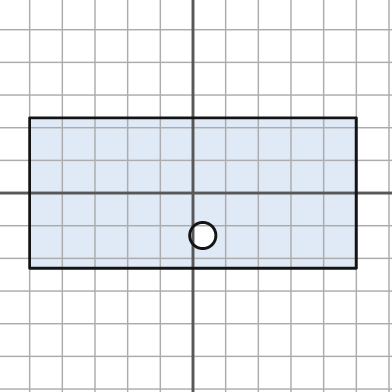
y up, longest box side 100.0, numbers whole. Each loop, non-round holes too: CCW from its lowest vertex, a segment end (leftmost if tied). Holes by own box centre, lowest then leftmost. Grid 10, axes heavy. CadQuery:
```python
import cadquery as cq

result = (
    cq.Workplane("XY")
    .moveTo(-50.0, -23.0)
    .lineTo(50.0, -23.0)
    .lineTo(50.0, 23.0)
    .lineTo(-50.0, 23.0)
    .close()
    .moveTo(3.0, -13.0)
    .circle(4.0)
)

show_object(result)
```